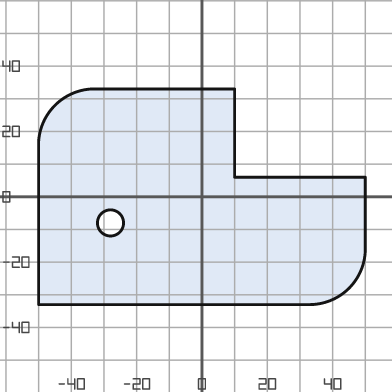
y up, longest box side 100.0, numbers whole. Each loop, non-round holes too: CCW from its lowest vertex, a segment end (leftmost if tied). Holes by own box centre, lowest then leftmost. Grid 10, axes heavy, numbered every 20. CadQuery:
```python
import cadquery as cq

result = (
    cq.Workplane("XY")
    .moveTo(-50.0, -33.0)
    .lineTo(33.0, -33.0)
    .threePointArc((45.0, -28.0), (50.0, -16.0))
    .lineTo(50.0, 6.0)
    .lineTo(10.0, 6.0)
    .lineTo(10.0, 33.0)
    .lineTo(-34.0, 33.0)
    .threePointArc((-45.0, 28.0), (-50.0, 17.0))
    .close()
    .moveTo(-28.0, -8.0)
    .circle(4.0)
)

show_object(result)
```